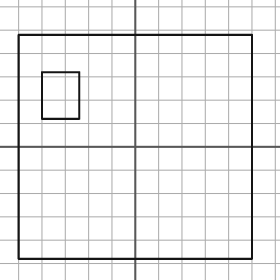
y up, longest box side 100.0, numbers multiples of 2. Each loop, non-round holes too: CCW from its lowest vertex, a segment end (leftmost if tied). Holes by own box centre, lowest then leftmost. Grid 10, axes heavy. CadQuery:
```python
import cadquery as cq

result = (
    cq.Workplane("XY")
    .moveTo(-50.0, -48.0)
    .lineTo(50.0, -48.0)
    .lineTo(50.0, 48.0)
    .lineTo(-50.0, 48.0)
    .close()
    .moveTo(-40.0, 12.0)
    .lineTo(-24.0, 12.0)
    .lineTo(-24.0, 32.0)
    .lineTo(-40.0, 32.0)
    .close()
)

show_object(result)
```